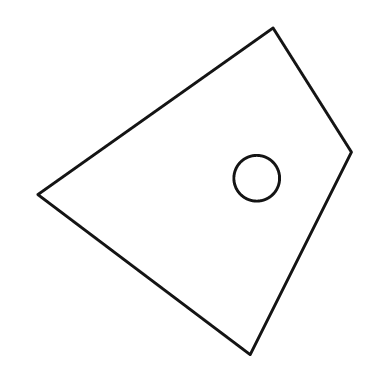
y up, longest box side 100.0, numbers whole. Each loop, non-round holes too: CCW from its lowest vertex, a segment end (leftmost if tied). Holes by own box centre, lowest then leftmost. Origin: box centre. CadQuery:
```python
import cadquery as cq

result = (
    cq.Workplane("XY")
    .moveTo(17.0, -50.0)
    .lineTo(48.0, 12.0)
    .lineTo(24.0, 50.0)
    .lineTo(-48.0, -1.0)
    .close()
    .moveTo(19.0, 4.0)
    .circle(7.0)
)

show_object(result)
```